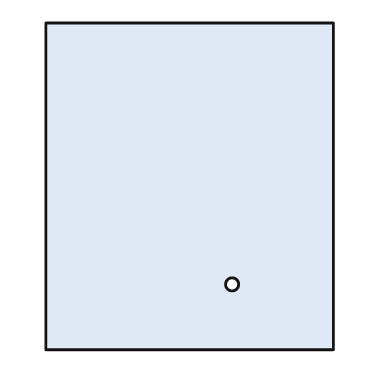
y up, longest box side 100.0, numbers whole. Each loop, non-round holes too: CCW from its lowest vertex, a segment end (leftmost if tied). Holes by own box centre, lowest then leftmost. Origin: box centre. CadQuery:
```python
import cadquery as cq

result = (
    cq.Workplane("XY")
    .moveTo(-44.0, -50.0)
    .lineTo(44.0, -50.0)
    .lineTo(44.0, 50.0)
    .lineTo(-44.0, 50.0)
    .close()
    .moveTo(13.0, -30.0)
    .circle(2.0)
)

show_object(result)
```